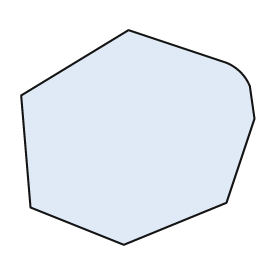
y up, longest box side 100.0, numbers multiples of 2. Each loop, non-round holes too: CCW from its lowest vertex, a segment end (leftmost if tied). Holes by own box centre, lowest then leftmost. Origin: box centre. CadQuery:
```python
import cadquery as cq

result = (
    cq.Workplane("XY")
    .moveTo(-6.0, -46.0)
    .lineTo(38.0, -28.0)
    .lineTo(50.0, 8.0)
    .lineTo(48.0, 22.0)
    .threePointArc((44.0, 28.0), (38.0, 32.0))
    .lineTo(-4.0, 46.0)
    .lineTo(-50.0, 18.0)
    .lineTo(-46.0, -30.0)
    .close()
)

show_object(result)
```